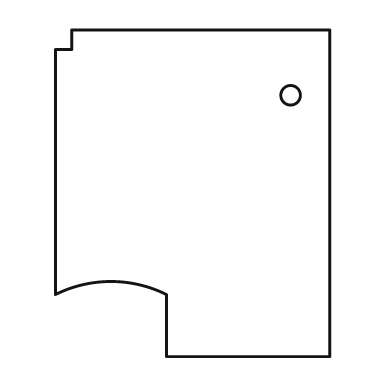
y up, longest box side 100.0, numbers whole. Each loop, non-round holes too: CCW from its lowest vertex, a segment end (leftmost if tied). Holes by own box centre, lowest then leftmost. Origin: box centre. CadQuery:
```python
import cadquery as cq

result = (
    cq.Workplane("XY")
    .moveTo(-8.0, -50.0)
    .lineTo(42.0, -50.0)
    .lineTo(42.0, 50.0)
    .lineTo(-37.0, 50.0)
    .lineTo(-37.0, 44.0)
    .lineTo(-42.0, 44.0)
    .lineTo(-42.0, -31.0)
    .threePointArc((-25.0, -27.0), (-8.0, -31.0))
    .close()
    .moveTo(30.0, 30.0)
    .circle(3.0)
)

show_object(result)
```